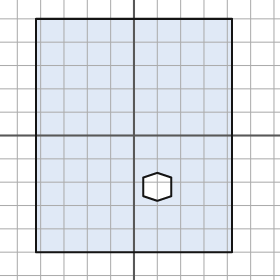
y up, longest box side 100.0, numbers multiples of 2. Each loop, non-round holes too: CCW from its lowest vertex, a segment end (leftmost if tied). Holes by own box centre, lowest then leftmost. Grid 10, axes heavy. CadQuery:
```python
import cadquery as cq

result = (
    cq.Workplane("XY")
    .moveTo(-42.0, -50.0)
    .lineTo(42.0, -50.0)
    .lineTo(42.0, 50.0)
    .lineTo(-42.0, 50.0)
    .close()
    .moveTo(10.0, -28.0)
    .lineTo(16.0, -26.0)
    .lineTo(16.0, -18.0)
    .lineTo(10.0, -16.0)
    .lineTo(4.0, -18.0)
    .lineTo(4.0, -26.0)
    .close()
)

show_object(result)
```